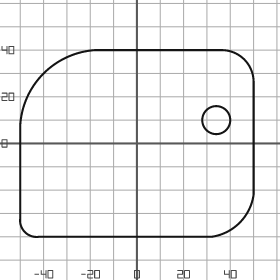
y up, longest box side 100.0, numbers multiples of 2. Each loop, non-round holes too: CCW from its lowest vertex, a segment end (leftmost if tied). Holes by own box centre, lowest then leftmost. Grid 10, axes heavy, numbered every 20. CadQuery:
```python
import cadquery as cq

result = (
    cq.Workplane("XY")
    .moveTo(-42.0, -40.0)
    .lineTo(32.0, -40.0)
    .threePointArc((44.0, -34.0), (50.0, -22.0))
    .lineTo(50.0, 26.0)
    .threePointArc((46.0, 36.0), (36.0, 40.0))
    .lineTo(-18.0, 40.0)
    .threePointArc((-40.0, 30.0), (-50.0, 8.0))
    .lineTo(-50.0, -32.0)
    .threePointArc((-48.0, -38.0), (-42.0, -40.0))
    .close()
    .moveTo(34.0, 10.0)
    .circle(6.0)
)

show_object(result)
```